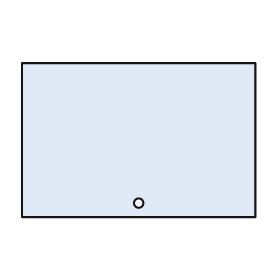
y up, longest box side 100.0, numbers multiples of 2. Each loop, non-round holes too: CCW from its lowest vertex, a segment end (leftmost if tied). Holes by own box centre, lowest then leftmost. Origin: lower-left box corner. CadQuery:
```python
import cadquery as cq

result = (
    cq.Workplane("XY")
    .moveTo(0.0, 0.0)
    .lineTo(100.0, 0.0)
    .lineTo(100.0, 66.0)
    .lineTo(0.0, 66.0)
    .close()
    .moveTo(50.0, 6.0)
    .circle(2.0)
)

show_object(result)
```